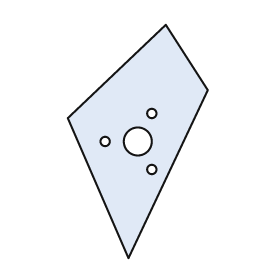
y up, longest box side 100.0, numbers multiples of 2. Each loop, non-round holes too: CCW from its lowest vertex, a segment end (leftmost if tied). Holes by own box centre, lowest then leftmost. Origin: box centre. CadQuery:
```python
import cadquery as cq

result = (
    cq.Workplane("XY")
    .moveTo(-4.0, -50.0)
    .lineTo(30.0, 22.0)
    .lineTo(12.0, 50.0)
    .lineTo(-30.0, 10.0)
    .close()
    .moveTo(6.0, -12.0)
    .circle(2.0)
    .moveTo(-14.0, 0.0)
    .circle(2.0)
    .moveTo(0.0, 0.0)
    .circle(6.0)
    .moveTo(6.0, 12.0)
    .circle(2.0)
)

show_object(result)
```